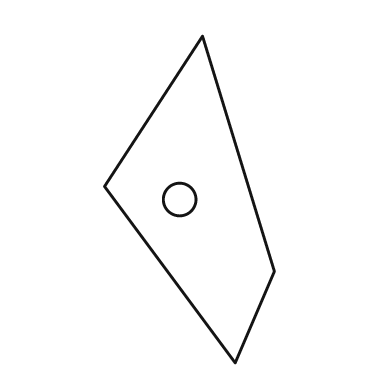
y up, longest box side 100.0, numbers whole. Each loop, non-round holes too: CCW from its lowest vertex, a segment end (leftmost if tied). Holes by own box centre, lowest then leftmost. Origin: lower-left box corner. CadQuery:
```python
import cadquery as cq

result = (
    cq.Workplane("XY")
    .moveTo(40.0, 0.0)
    .lineTo(52.0, 28.0)
    .lineTo(30.0, 100.0)
    .lineTo(0.0, 54.0)
    .close()
    .moveTo(23.0, 50.0)
    .circle(5.0)
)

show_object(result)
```